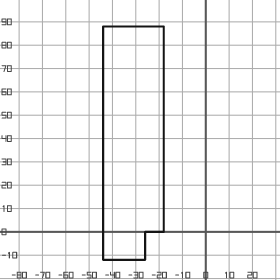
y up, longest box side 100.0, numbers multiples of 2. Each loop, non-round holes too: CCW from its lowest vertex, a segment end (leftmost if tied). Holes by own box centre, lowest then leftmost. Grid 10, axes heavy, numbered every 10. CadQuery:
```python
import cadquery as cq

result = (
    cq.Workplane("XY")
    .moveTo(-44.0, -12.0)
    .lineTo(-26.0, -12.0)
    .lineTo(-26.0, 0.0)
    .lineTo(-18.0, 0.0)
    .lineTo(-18.0, 88.0)
    .lineTo(-44.0, 88.0)
    .close()
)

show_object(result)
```